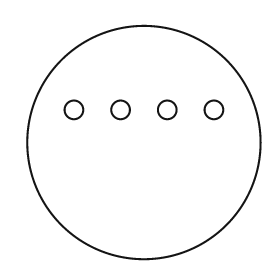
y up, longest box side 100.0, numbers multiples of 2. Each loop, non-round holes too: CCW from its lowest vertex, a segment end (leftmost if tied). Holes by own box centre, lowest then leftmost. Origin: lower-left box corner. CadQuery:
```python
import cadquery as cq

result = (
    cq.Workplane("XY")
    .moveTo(50.0, 50.0)
    .circle(50.0)
    .moveTo(20.0, 64.0)
    .circle(4.0)
    .moveTo(40.0, 64.0)
    .circle(4.0)
    .moveTo(60.0, 64.0)
    .circle(4.0)
    .moveTo(80.0, 64.0)
    .circle(4.0)
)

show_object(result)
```